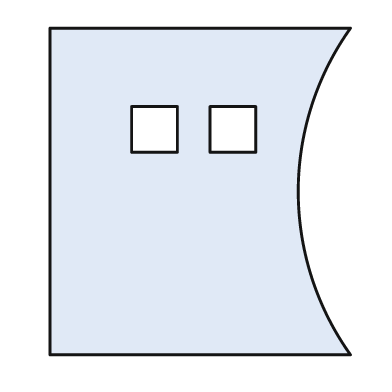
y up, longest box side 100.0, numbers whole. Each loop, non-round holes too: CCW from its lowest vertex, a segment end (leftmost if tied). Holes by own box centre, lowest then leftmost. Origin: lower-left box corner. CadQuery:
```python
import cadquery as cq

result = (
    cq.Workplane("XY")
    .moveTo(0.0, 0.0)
    .lineTo(92.0, 0.0)
    .threePointArc((76.0, 50.0), (92.0, 100.0))
    .lineTo(0.0, 100.0)
    .close()
    .moveTo(25.0, 62.0)
    .lineTo(39.0, 62.0)
    .lineTo(39.0, 76.0)
    .lineTo(25.0, 76.0)
    .close()
    .moveTo(49.0, 62.0)
    .lineTo(63.0, 62.0)
    .lineTo(63.0, 76.0)
    .lineTo(49.0, 76.0)
    .close()
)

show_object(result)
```